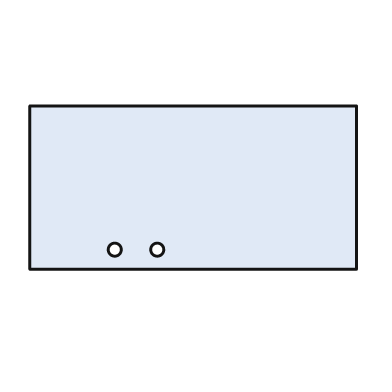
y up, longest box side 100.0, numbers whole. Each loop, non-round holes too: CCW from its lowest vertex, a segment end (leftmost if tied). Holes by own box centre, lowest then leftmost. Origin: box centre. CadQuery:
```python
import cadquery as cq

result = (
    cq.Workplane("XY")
    .moveTo(-50.0, -25.0)
    .lineTo(50.0, -25.0)
    .lineTo(50.0, 25.0)
    .lineTo(-50.0, 25.0)
    .close()
    .moveTo(-24.0, -19.0)
    .circle(2.0)
    .moveTo(-11.0, -19.0)
    .circle(2.0)
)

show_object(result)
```